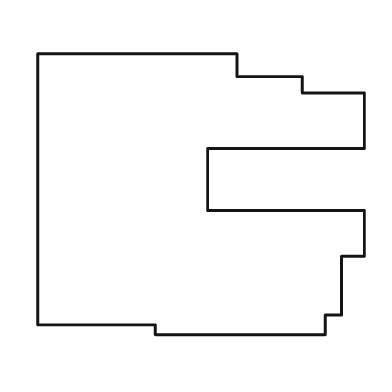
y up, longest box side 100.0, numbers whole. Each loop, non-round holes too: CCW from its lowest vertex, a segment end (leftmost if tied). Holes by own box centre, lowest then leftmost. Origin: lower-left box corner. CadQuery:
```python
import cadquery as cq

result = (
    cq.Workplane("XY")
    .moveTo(36.0, 0.0)
    .lineTo(88.0, 0.0)
    .lineTo(88.0, 6.0)
    .lineTo(93.0, 6.0)
    .lineTo(93.0, 24.0)
    .lineTo(100.0, 24.0)
    .lineTo(100.0, 38.0)
    .lineTo(52.0, 38.0)
    .lineTo(52.0, 57.0)
    .lineTo(100.0, 57.0)
    .lineTo(100.0, 74.0)
    .lineTo(81.0, 74.0)
    .lineTo(81.0, 79.0)
    .lineTo(61.0, 79.0)
    .lineTo(61.0, 86.0)
    .lineTo(0.0, 86.0)
    .lineTo(0.0, 3.0)
    .lineTo(36.0, 3.0)
    .close()
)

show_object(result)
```